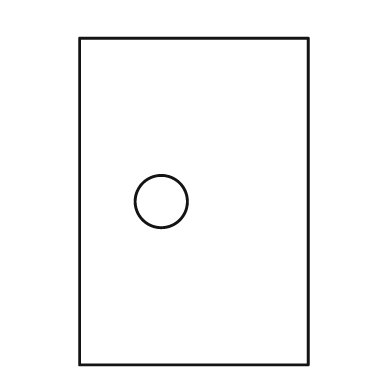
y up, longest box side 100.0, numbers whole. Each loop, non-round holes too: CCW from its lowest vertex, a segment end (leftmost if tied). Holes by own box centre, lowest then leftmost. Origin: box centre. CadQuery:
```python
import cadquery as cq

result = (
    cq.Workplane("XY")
    .moveTo(-35.0, -50.0)
    .lineTo(35.0, -50.0)
    .lineTo(35.0, 50.0)
    .lineTo(-35.0, 50.0)
    .close()
    .moveTo(-10.0, 0.0)
    .circle(8.0)
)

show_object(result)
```